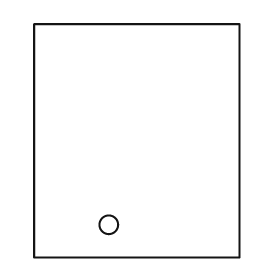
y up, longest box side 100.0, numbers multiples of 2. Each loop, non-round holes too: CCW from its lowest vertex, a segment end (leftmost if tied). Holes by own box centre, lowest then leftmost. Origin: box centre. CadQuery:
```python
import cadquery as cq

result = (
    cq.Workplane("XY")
    .moveTo(-44.0, -50.0)
    .lineTo(44.0, -50.0)
    .lineTo(44.0, 50.0)
    .lineTo(-44.0, 50.0)
    .close()
    .moveTo(-12.0, -36.0)
    .circle(4.0)
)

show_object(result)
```